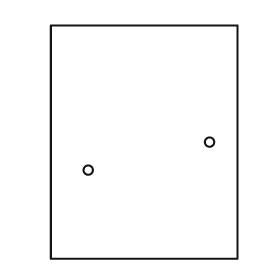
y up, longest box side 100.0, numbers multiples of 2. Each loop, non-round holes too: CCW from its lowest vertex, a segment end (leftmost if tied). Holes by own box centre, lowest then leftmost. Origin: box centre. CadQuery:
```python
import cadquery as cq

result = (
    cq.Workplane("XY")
    .moveTo(-40.0, -50.0)
    .lineTo(40.0, -50.0)
    .lineTo(40.0, 50.0)
    .lineTo(-40.0, 50.0)
    .close()
    .moveTo(-24.0, -12.0)
    .circle(2.0)
    .moveTo(28.0, 0.0)
    .circle(2.0)
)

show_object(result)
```